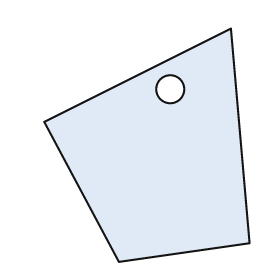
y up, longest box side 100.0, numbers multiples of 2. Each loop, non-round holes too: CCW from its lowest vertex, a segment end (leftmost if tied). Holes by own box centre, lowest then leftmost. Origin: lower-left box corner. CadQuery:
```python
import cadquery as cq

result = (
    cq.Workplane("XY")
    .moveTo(32.0, 0.0)
    .lineTo(88.0, 8.0)
    .lineTo(80.0, 100.0)
    .lineTo(0.0, 60.0)
    .close()
    .moveTo(54.0, 74.0)
    .circle(6.0)
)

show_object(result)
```